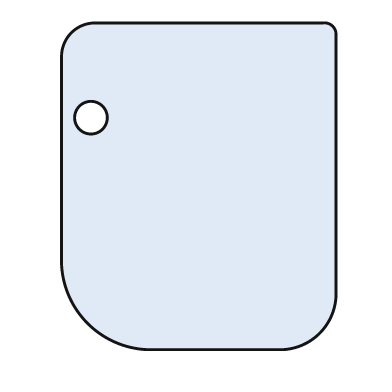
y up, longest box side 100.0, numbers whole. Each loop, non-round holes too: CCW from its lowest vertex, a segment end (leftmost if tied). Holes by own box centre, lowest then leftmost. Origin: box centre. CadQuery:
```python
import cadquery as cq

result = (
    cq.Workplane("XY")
    .moveTo(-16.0, -50.0)
    .lineTo(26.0, -50.0)
    .threePointArc((37.0, -45.0), (42.0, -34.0))
    .lineTo(42.0, 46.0)
    .threePointArc((41.0, 49.0), (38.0, 50.0))
    .lineTo(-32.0, 50.0)
    .threePointArc((-39.0, 47.0), (-42.0, 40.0))
    .lineTo(-42.0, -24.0)
    .threePointArc((-34.0, -42.0), (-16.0, -50.0))
    .close()
    .moveTo(-33.0, 21.0)
    .circle(5.0)
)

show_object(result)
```